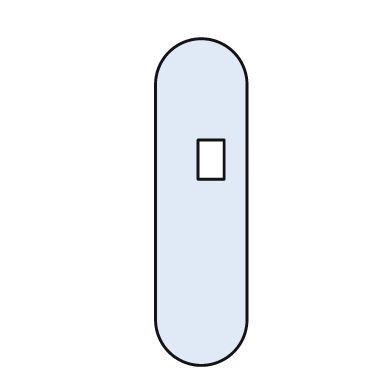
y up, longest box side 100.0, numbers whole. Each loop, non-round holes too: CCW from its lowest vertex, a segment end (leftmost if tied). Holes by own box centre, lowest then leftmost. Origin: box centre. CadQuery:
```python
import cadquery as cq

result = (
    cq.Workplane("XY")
    .moveTo(-14.0, -36.0)
    .threePointArc((0.0, -50.0), (14.0, -36.0))
    .lineTo(14.0, 36.0)
    .threePointArc((0.0, 50.0), (-14.0, 36.0))
    .close()
    .moveTo(-1.0, 7.0)
    .lineTo(7.0, 7.0)
    .lineTo(7.0, 19.0)
    .lineTo(-1.0, 19.0)
    .close()
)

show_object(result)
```